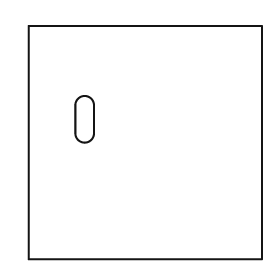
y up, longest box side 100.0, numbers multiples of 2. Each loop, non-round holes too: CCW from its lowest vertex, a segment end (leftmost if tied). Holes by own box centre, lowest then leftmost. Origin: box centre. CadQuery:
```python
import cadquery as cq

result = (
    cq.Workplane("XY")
    .moveTo(-50.0, -50.0)
    .lineTo(50.0, -50.0)
    .lineTo(50.0, 50.0)
    .lineTo(-50.0, 50.0)
    .close()
    .moveTo(-30.0, 4.0)
    .threePointArc((-26.0, 0.0), (-22.0, 4.0))
    .lineTo(-22.0, 16.0)
    .threePointArc((-26.0, 20.0), (-30.0, 16.0))
    .close()
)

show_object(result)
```